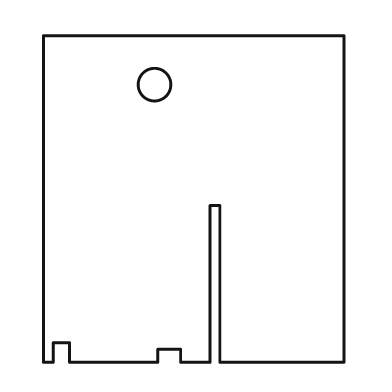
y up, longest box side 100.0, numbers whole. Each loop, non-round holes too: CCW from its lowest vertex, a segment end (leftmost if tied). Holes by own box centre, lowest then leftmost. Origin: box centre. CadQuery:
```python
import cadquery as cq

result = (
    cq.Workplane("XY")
    .moveTo(-46.0, -50.0)
    .lineTo(-43.0, -50.0)
    .lineTo(-43.0, -44.0)
    .lineTo(-38.0, -44.0)
    .lineTo(-38.0, -50.0)
    .lineTo(-11.0, -50.0)
    .lineTo(-11.0, -46.0)
    .lineTo(-4.0, -46.0)
    .lineTo(-4.0, -50.0)
    .lineTo(5.0, -50.0)
    .lineTo(5.0, -2.0)
    .lineTo(8.0, -2.0)
    .lineTo(8.0, -50.0)
    .lineTo(46.0, -50.0)
    .lineTo(46.0, 50.0)
    .lineTo(-46.0, 50.0)
    .close()
    .moveTo(-12.0, 35.0)
    .circle(5.0)
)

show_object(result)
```